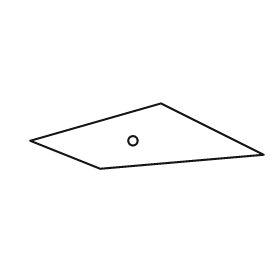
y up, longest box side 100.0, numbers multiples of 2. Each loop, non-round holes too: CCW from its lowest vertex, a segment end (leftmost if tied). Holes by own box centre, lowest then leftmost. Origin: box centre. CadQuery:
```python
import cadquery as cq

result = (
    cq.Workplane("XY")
    .moveTo(-20.0, -14.0)
    .lineTo(50.0, -8.0)
    .lineTo(6.0, 14.0)
    .lineTo(-50.0, -2.0)
    .close()
    .moveTo(-6.0, -2.0)
    .circle(2.0)
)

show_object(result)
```